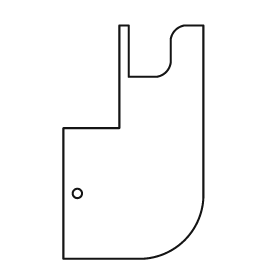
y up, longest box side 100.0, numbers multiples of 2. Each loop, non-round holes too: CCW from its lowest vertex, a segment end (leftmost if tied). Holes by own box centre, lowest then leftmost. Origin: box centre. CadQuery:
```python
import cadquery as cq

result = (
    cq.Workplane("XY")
    .moveTo(-30.0, -50.0)
    .lineTo(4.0, -50.0)
    .threePointArc((22.0, -42.0), (30.0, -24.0))
    .lineTo(30.0, 50.0)
    .lineTo(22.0, 50.0)
    .threePointArc((18.0, 48.0), (16.0, 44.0))
    .lineTo(16.0, 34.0)
    .threePointArc((14.0, 30.0), (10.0, 28.0))
    .lineTo(-2.0, 28.0)
    .lineTo(-2.0, 50.0)
    .lineTo(-6.0, 50.0)
    .lineTo(-6.0, 6.0)
    .lineTo(-30.0, 6.0)
    .close()
    .moveTo(-24.0, -22.0)
    .circle(2.0)
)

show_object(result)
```